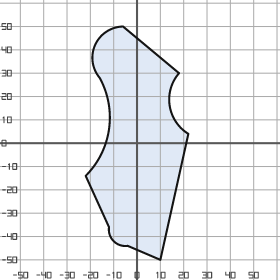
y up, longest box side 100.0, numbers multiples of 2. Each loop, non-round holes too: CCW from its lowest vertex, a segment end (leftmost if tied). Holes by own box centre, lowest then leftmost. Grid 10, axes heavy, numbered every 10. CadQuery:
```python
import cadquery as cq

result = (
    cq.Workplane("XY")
    .moveTo(10.0, -50.0)
    .lineTo(22.0, 4.0)
    .threePointArc((14.0, 16.0), (18.0, 30.0))
    .lineTo(-6.0, 50.0)
    .threePointArc((-18.0, 42.0), (-16.0, 28.0))
    .threePointArc((-12.0, 6.0), (-22.0, -14.0))
    .lineTo(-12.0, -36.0)
    .threePointArc((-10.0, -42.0), (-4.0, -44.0))
    .close()
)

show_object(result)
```